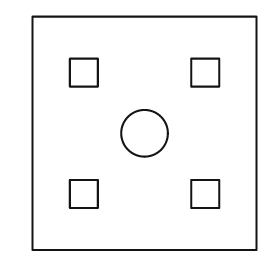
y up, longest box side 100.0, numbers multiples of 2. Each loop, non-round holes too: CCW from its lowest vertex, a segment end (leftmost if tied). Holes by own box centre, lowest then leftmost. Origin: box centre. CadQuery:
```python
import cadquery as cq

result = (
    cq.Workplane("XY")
    .moveTo(-48.0, -50.0)
    .lineTo(48.0, -50.0)
    .lineTo(48.0, 50.0)
    .lineTo(-48.0, 50.0)
    .close()
    .moveTo(-32.0, -32.0)
    .lineTo(-20.0, -32.0)
    .lineTo(-20.0, -20.0)
    .lineTo(-32.0, -20.0)
    .close()
    .moveTo(20.0, -32.0)
    .lineTo(32.0, -32.0)
    .lineTo(32.0, -20.0)
    .lineTo(20.0, -20.0)
    .close()
    .moveTo(0.0, 0.0)
    .circle(10.0)
    .moveTo(-32.0, 20.0)
    .lineTo(-20.0, 20.0)
    .lineTo(-20.0, 32.0)
    .lineTo(-32.0, 32.0)
    .close()
    .moveTo(20.0, 20.0)
    .lineTo(32.0, 20.0)
    .lineTo(32.0, 32.0)
    .lineTo(20.0, 32.0)
    .close()
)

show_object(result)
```